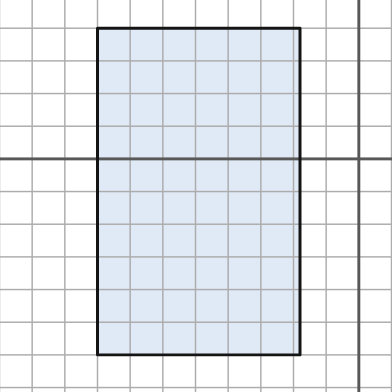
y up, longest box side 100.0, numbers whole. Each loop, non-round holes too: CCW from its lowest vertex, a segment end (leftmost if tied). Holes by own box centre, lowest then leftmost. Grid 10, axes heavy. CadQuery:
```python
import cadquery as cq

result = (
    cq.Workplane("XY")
    .moveTo(-80.0, -60.0)
    .lineTo(-18.0, -60.0)
    .lineTo(-18.0, 40.0)
    .lineTo(-80.0, 40.0)
    .close()
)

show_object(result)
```